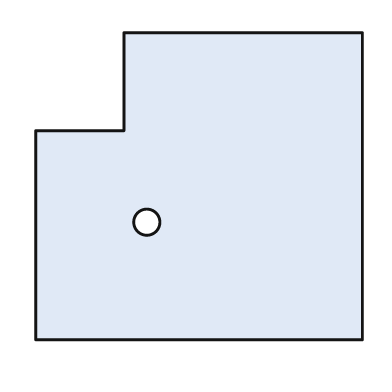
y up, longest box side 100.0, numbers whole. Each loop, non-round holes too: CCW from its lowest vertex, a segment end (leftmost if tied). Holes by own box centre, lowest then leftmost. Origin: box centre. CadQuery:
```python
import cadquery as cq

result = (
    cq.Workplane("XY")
    .moveTo(-50.0, -47.0)
    .lineTo(50.0, -47.0)
    .lineTo(50.0, 47.0)
    .lineTo(-23.0, 47.0)
    .lineTo(-23.0, 17.0)
    .lineTo(-50.0, 17.0)
    .close()
    .moveTo(-16.0, -11.0)
    .circle(4.0)
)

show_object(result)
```